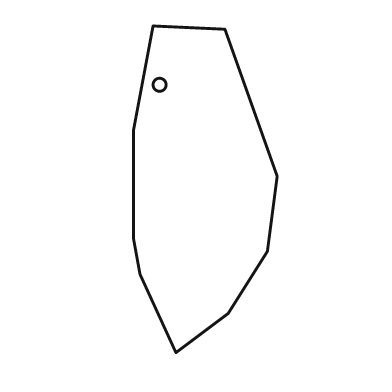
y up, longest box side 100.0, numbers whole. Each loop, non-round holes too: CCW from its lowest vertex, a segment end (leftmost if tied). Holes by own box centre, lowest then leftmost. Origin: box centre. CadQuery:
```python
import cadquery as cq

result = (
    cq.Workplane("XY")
    .moveTo(-9.0, -50.0)
    .lineTo(7.0, -38.0)
    .lineTo(19.0, -19.0)
    .lineTo(22.0, 4.0)
    .lineTo(6.0, 49.0)
    .lineTo(-16.0, 50.0)
    .lineTo(-22.0, 18.0)
    .lineTo(-22.0, -15.0)
    .lineTo(-20.0, -26.0)
    .close()
    .moveTo(-14.0, 32.0)
    .circle(2.0)
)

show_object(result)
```